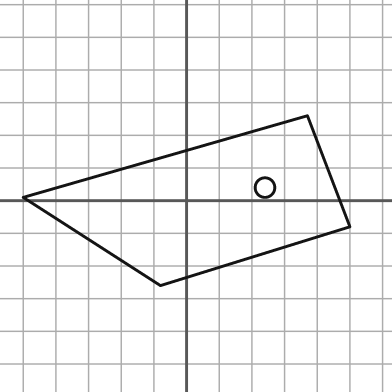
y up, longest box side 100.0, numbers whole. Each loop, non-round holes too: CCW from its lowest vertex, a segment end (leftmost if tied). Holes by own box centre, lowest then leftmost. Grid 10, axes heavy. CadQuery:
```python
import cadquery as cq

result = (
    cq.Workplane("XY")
    .moveTo(-8.0, -26.0)
    .lineTo(50.0, -8.0)
    .lineTo(37.0, 26.0)
    .lineTo(-50.0, 1.0)
    .close()
    .moveTo(24.0, 4.0)
    .circle(3.0)
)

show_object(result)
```